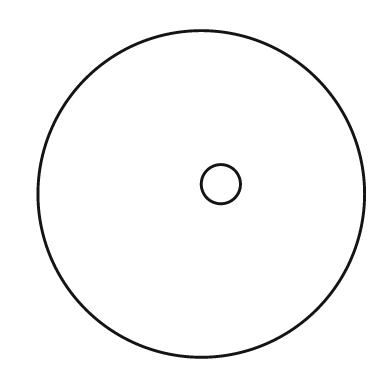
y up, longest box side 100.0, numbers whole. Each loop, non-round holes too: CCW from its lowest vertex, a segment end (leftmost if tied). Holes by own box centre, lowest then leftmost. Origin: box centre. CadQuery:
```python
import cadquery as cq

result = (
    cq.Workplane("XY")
    .moveTo(0.0, 0.0)
    .circle(50.0)
    .moveTo(6.0, 3.0)
    .circle(6.0)
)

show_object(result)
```